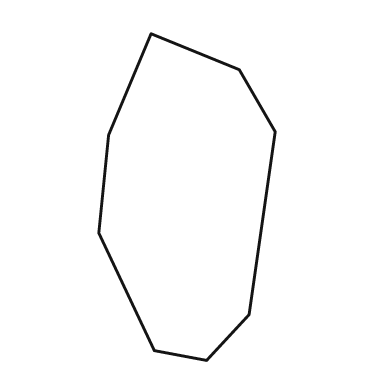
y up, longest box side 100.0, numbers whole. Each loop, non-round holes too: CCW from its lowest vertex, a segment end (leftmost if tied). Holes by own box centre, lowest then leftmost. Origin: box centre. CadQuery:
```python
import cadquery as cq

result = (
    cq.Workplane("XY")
    .moveTo(6.0, -50.0)
    .lineTo(19.0, -36.0)
    .lineTo(27.0, 20.0)
    .lineTo(16.0, 39.0)
    .lineTo(-11.0, 50.0)
    .lineTo(-24.0, 19.0)
    .lineTo(-27.0, -11.0)
    .lineTo(-10.0, -47.0)
    .close()
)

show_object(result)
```